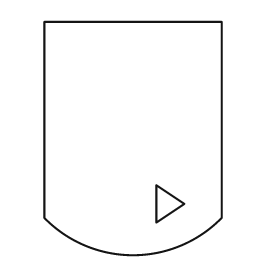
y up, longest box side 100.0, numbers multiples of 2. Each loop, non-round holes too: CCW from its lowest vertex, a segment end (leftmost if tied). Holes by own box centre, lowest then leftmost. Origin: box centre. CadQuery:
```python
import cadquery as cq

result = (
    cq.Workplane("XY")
    .moveTo(-38.0, -34.0)
    .threePointArc((0.0, -50.0), (38.0, -34.0))
    .lineTo(38.0, 50.0)
    .lineTo(-38.0, 50.0)
    .close()
    .moveTo(10.0, -36.0)
    .lineTo(22.0, -28.0)
    .lineTo(10.0, -20.0)
    .close()
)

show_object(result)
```